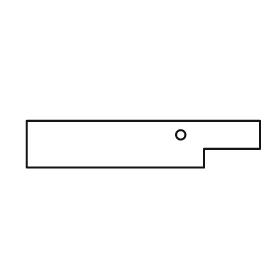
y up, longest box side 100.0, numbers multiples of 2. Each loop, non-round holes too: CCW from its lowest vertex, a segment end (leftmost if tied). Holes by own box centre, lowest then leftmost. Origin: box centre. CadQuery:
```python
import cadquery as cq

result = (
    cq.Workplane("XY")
    .moveTo(-50.0, -10.0)
    .lineTo(26.0, -10.0)
    .lineTo(26.0, -2.0)
    .lineTo(50.0, -2.0)
    .lineTo(50.0, 10.0)
    .lineTo(-50.0, 10.0)
    .close()
    .moveTo(16.0, 4.0)
    .circle(2.0)
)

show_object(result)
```